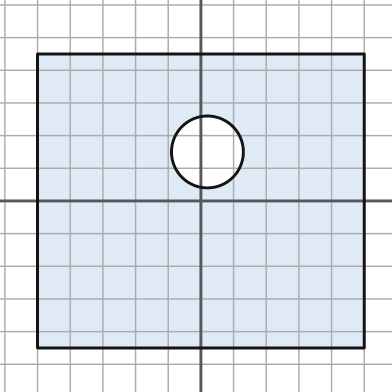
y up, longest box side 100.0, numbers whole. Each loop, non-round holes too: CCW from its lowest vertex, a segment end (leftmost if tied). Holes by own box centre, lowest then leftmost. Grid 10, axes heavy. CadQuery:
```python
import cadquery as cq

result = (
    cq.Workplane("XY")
    .moveTo(-50.0, -45.0)
    .lineTo(50.0, -45.0)
    .lineTo(50.0, 45.0)
    .lineTo(-50.0, 45.0)
    .close()
    .moveTo(2.0, 15.0)
    .circle(11.0)
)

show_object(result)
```